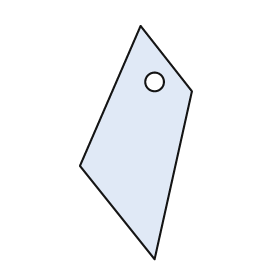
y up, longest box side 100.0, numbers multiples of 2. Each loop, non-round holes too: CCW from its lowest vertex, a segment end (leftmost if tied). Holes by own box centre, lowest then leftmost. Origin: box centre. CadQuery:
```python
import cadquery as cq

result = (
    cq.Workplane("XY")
    .moveTo(8.0, -50.0)
    .lineTo(24.0, 22.0)
    .lineTo(2.0, 50.0)
    .lineTo(-24.0, -10.0)
    .close()
    .moveTo(8.0, 26.0)
    .circle(4.0)
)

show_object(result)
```